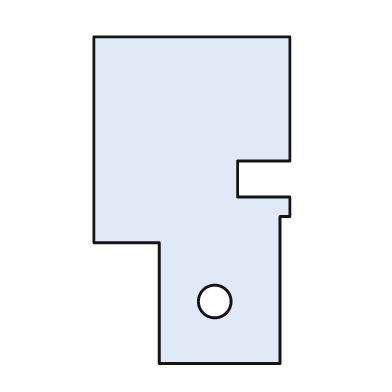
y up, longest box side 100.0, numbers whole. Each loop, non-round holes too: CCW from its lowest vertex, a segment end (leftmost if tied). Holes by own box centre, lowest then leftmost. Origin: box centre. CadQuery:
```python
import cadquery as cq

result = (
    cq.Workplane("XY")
    .moveTo(-10.0, -50.0)
    .lineTo(27.0, -50.0)
    .lineTo(27.0, -5.0)
    .lineTo(30.0, -5.0)
    .lineTo(30.0, 1.0)
    .lineTo(14.0, 1.0)
    .lineTo(14.0, 12.0)
    .lineTo(30.0, 12.0)
    .lineTo(30.0, 50.0)
    .lineTo(-30.0, 50.0)
    .lineTo(-30.0, -13.0)
    .lineTo(-10.0, -13.0)
    .close()
    .moveTo(7.0, -31.0)
    .circle(5.0)
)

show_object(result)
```